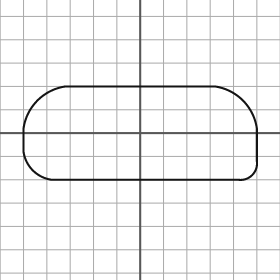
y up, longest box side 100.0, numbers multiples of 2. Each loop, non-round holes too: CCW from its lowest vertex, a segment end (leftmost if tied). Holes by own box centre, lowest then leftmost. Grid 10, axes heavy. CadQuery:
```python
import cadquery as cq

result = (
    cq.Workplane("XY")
    .moveTo(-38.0, -20.0)
    .lineTo(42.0, -20.0)
    .threePointArc((48.0, -18.0), (50.0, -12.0))
    .lineTo(50.0, 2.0)
    .threePointArc((44.0, 14.0), (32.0, 20.0))
    .lineTo(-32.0, 20.0)
    .threePointArc((-44.0, 14.0), (-50.0, 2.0))
    .lineTo(-50.0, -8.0)
    .threePointArc((-46.0, -16.0), (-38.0, -20.0))
    .close()
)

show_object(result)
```